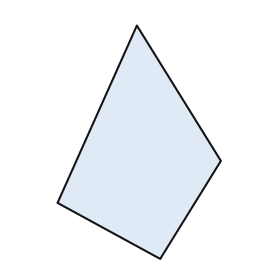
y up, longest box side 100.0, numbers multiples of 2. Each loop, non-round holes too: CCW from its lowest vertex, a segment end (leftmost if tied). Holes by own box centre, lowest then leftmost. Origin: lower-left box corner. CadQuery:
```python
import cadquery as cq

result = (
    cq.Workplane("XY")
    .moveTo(44.0, 0.0)
    .lineTo(70.0, 42.0)
    .lineTo(34.0, 100.0)
    .lineTo(0.0, 24.0)
    .close()
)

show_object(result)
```